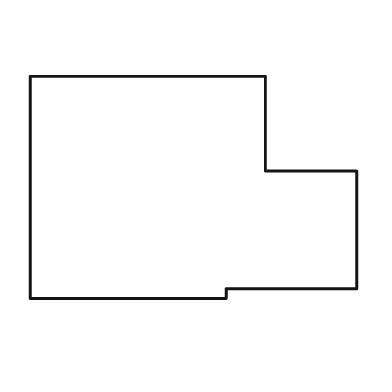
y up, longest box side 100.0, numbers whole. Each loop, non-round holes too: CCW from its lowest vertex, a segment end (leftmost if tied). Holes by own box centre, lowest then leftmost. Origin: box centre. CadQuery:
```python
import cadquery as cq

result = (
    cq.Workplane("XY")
    .moveTo(-50.0, -34.0)
    .lineTo(10.0, -34.0)
    .lineTo(10.0, -31.0)
    .lineTo(50.0, -31.0)
    .lineTo(50.0, 5.0)
    .lineTo(22.0, 5.0)
    .lineTo(22.0, 34.0)
    .lineTo(-50.0, 34.0)
    .close()
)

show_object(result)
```